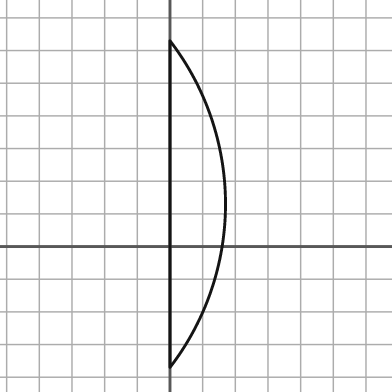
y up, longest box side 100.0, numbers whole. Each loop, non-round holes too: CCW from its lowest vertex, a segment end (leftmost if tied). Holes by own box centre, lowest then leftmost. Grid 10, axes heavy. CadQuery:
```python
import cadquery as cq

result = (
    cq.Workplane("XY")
    .moveTo(0.0, -37.0)
    .threePointArc((17.0, 13.0), (0.0, 63.0))
    .close()
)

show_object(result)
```